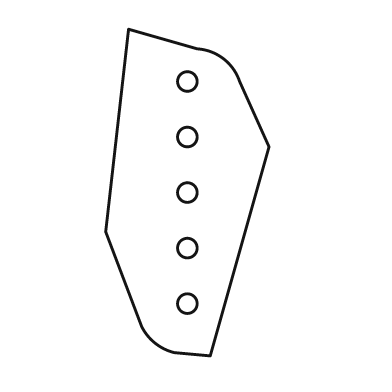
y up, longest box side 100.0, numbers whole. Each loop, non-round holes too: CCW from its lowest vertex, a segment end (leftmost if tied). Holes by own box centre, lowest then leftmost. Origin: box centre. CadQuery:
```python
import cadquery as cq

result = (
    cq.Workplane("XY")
    .moveTo(7.0, -50.0)
    .lineTo(25.0, 14.0)
    .lineTo(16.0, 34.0)
    .threePointArc((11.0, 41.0), (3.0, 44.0))
    .lineTo(-18.0, 50.0)
    .lineTo(-25.0, -12.0)
    .lineTo(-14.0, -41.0)
    .threePointArc((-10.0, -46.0), (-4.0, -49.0))
    .close()
    .moveTo(0.0, -34.0)
    .circle(3.0)
    .moveTo(0.0, -17.0)
    .circle(3.0)
    .moveTo(0.0, 0.0)
    .circle(3.0)
    .moveTo(0.0, 17.0)
    .circle(3.0)
    .moveTo(0.0, 34.0)
    .circle(3.0)
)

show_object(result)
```